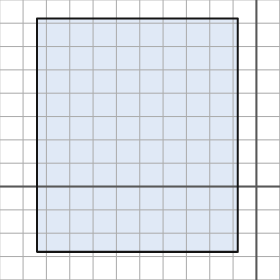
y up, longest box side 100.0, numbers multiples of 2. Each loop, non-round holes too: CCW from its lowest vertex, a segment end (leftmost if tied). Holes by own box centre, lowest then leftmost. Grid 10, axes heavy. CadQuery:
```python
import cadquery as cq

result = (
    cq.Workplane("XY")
    .moveTo(-94.0, -28.0)
    .lineTo(-8.0, -28.0)
    .lineTo(-8.0, 72.0)
    .lineTo(-94.0, 72.0)
    .close()
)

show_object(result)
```